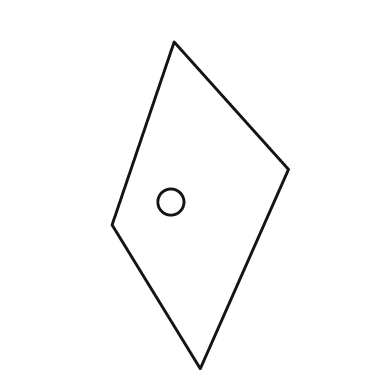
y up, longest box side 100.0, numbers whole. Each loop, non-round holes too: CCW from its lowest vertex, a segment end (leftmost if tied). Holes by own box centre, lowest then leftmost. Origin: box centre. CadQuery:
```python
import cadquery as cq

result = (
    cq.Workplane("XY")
    .moveTo(0.0, -50.0)
    .lineTo(27.0, 11.0)
    .lineTo(-8.0, 50.0)
    .lineTo(-27.0, -6.0)
    .close()
    .moveTo(-9.0, 1.0)
    .circle(4.0)
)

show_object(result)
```